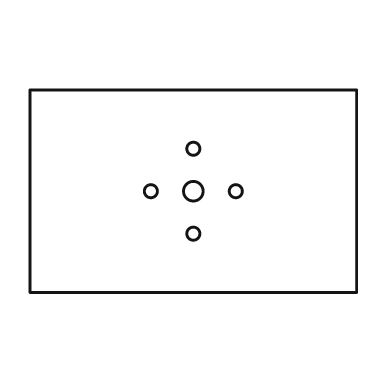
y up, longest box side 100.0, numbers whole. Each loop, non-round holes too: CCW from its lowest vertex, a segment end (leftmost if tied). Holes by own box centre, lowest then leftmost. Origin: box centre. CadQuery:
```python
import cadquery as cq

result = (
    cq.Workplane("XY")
    .moveTo(-50.0, -31.0)
    .lineTo(50.0, -31.0)
    .lineTo(50.0, 31.0)
    .lineTo(-50.0, 31.0)
    .close()
    .moveTo(0.0, -13.0)
    .circle(2.0)
    .moveTo(-13.0, 0.0)
    .circle(2.0)
    .moveTo(0.0, 0.0)
    .circle(3.0)
    .moveTo(13.0, 0.0)
    .circle(2.0)
    .moveTo(0.0, 13.0)
    .circle(2.0)
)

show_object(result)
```